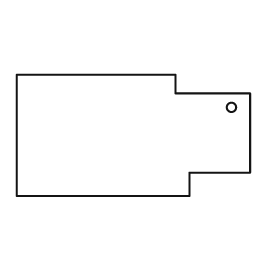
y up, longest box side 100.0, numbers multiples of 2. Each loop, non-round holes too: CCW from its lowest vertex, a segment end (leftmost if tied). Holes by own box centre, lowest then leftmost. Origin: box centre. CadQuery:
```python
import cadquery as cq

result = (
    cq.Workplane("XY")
    .moveTo(-50.0, -26.0)
    .lineTo(24.0, -26.0)
    .lineTo(24.0, -16.0)
    .lineTo(50.0, -16.0)
    .lineTo(50.0, 18.0)
    .lineTo(18.0, 18.0)
    .lineTo(18.0, 26.0)
    .lineTo(-50.0, 26.0)
    .close()
    .moveTo(42.0, 12.0)
    .circle(2.0)
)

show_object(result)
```